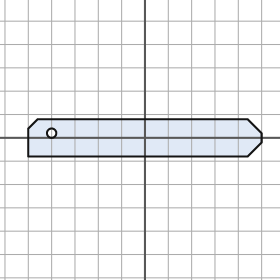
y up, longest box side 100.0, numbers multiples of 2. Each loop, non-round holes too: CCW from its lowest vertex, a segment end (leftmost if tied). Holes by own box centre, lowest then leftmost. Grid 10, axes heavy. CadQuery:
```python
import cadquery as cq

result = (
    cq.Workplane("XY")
    .moveTo(-50.0, -8.0)
    .lineTo(44.0, -8.0)
    .lineTo(50.0, -2.0)
    .lineTo(50.0, 2.0)
    .lineTo(44.0, 8.0)
    .lineTo(-46.0, 8.0)
    .lineTo(-50.0, 4.0)
    .close()
    .moveTo(-40.0, 2.0)
    .circle(2.0)
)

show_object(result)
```